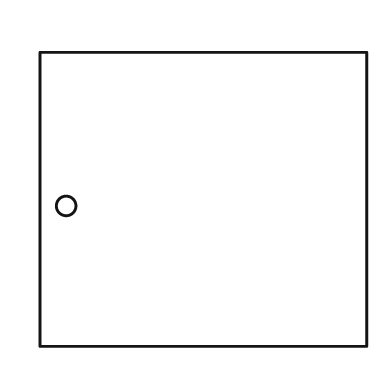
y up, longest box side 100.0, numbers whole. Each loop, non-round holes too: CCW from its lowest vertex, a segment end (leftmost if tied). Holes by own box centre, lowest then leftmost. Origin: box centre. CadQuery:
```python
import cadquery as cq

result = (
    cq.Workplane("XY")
    .moveTo(-50.0, -45.0)
    .lineTo(50.0, -45.0)
    .lineTo(50.0, 45.0)
    .lineTo(-50.0, 45.0)
    .close()
    .moveTo(-42.0, -2.0)
    .circle(3.0)
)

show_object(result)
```